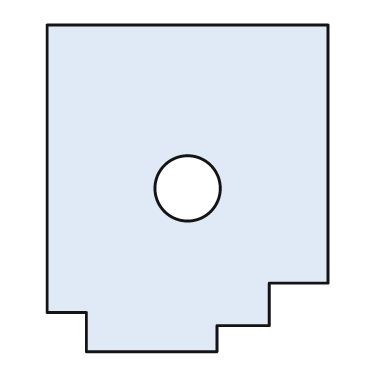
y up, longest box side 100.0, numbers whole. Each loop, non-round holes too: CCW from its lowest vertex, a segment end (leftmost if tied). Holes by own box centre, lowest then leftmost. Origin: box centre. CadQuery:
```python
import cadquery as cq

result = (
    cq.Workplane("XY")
    .moveTo(-31.0, -50.0)
    .lineTo(9.0, -50.0)
    .lineTo(9.0, -42.0)
    .lineTo(25.0, -42.0)
    .lineTo(25.0, -29.0)
    .lineTo(43.0, -29.0)
    .lineTo(43.0, 50.0)
    .lineTo(-43.0, 50.0)
    .lineTo(-43.0, -38.0)
    .lineTo(-31.0, -38.0)
    .close()
    .moveTo(0.0, 0.0)
    .circle(10.0)
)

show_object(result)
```